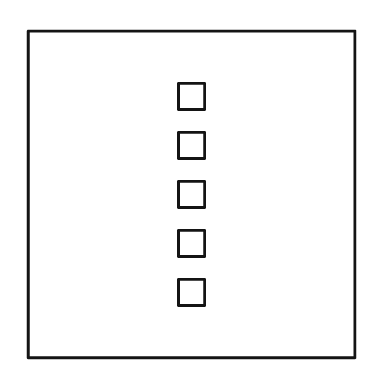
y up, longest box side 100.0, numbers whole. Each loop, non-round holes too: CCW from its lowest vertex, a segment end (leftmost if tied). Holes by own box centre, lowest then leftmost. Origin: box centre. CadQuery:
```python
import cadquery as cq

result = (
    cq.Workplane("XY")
    .moveTo(-50.0, -50.0)
    .lineTo(50.0, -50.0)
    .lineTo(50.0, 50.0)
    .lineTo(-50.0, 50.0)
    .close()
    .moveTo(-4.0, -34.0)
    .lineTo(4.0, -34.0)
    .lineTo(4.0, -26.0)
    .lineTo(-4.0, -26.0)
    .close()
    .moveTo(-4.0, -19.0)
    .lineTo(4.0, -19.0)
    .lineTo(4.0, -11.0)
    .lineTo(-4.0, -11.0)
    .close()
    .moveTo(-4.0, -4.0)
    .lineTo(4.0, -4.0)
    .lineTo(4.0, 4.0)
    .lineTo(-4.0, 4.0)
    .close()
    .moveTo(-4.0, 11.0)
    .lineTo(4.0, 11.0)
    .lineTo(4.0, 19.0)
    .lineTo(-4.0, 19.0)
    .close()
    .moveTo(-4.0, 26.0)
    .lineTo(4.0, 26.0)
    .lineTo(4.0, 34.0)
    .lineTo(-4.0, 34.0)
    .close()
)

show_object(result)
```